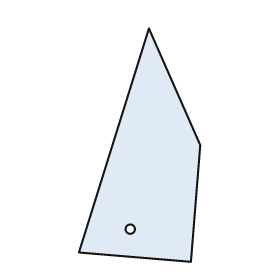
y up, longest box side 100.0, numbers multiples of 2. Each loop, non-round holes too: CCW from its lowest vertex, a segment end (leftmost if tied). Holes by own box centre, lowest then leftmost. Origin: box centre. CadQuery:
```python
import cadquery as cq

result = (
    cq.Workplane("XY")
    .moveTo(22.0, -50.0)
    .lineTo(26.0, 0.0)
    .lineTo(4.0, 50.0)
    .lineTo(-26.0, -46.0)
    .close()
    .moveTo(-4.0, -36.0)
    .circle(2.0)
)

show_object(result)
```